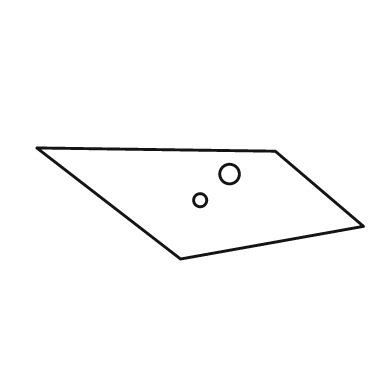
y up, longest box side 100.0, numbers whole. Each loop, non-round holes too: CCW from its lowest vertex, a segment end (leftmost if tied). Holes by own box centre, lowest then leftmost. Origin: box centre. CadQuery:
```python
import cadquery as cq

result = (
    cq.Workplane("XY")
    .moveTo(-6.0, -17.0)
    .lineTo(50.0, -7.0)
    .lineTo(23.0, 16.0)
    .lineTo(-50.0, 17.0)
    .close()
    .moveTo(0.0, 1.0)
    .circle(2.0)
    .moveTo(9.0, 9.0)
    .circle(3.0)
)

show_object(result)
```